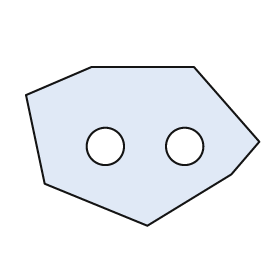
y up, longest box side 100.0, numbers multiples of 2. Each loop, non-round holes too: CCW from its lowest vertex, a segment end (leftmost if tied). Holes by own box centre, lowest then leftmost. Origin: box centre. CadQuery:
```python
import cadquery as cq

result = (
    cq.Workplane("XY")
    .moveTo(2.0, -34.0)
    .lineTo(38.0, -12.0)
    .lineTo(50.0, 2.0)
    .lineTo(22.0, 34.0)
    .lineTo(-22.0, 34.0)
    .lineTo(-50.0, 22.0)
    .lineTo(-42.0, -16.0)
    .close()
    .moveTo(-16.0, 0.0)
    .circle(8.0)
    .moveTo(18.0, 0.0)
    .circle(8.0)
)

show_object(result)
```